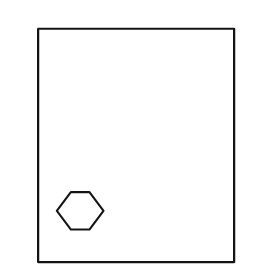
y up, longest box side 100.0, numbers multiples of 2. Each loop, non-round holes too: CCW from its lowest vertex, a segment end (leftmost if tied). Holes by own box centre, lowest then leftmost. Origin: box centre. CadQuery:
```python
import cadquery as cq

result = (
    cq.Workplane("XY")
    .moveTo(-42.0, -50.0)
    .lineTo(42.0, -50.0)
    .lineTo(42.0, 50.0)
    .lineTo(-42.0, 50.0)
    .close()
    .moveTo(-28.0, -36.0)
    .lineTo(-20.0, -36.0)
    .lineTo(-14.0, -28.0)
    .lineTo(-20.0, -20.0)
    .lineTo(-28.0, -20.0)
    .lineTo(-34.0, -28.0)
    .close()
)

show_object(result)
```